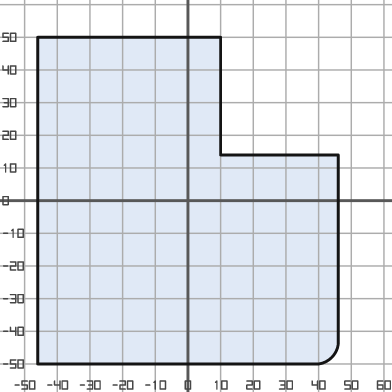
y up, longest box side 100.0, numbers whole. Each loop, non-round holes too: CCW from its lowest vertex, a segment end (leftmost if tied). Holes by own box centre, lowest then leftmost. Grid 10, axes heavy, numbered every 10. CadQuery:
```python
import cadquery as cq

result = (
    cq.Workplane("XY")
    .moveTo(-46.0, -50.0)
    .lineTo(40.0, -50.0)
    .threePointArc((44.0, -48.0), (46.0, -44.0))
    .lineTo(46.0, 14.0)
    .lineTo(10.0, 14.0)
    .lineTo(10.0, 50.0)
    .lineTo(-46.0, 50.0)
    .close()
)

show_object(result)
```